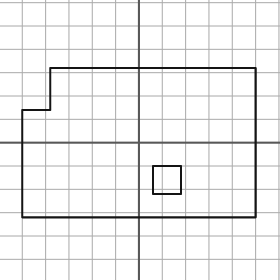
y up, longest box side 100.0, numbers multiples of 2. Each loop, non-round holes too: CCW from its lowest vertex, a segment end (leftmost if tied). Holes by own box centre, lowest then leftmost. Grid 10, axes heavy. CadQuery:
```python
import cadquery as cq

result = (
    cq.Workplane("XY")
    .moveTo(-50.0, -32.0)
    .lineTo(50.0, -32.0)
    .lineTo(50.0, 32.0)
    .lineTo(-38.0, 32.0)
    .lineTo(-38.0, 14.0)
    .lineTo(-50.0, 14.0)
    .close()
    .moveTo(6.0, -22.0)
    .lineTo(18.0, -22.0)
    .lineTo(18.0, -10.0)
    .lineTo(6.0, -10.0)
    .close()
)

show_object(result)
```